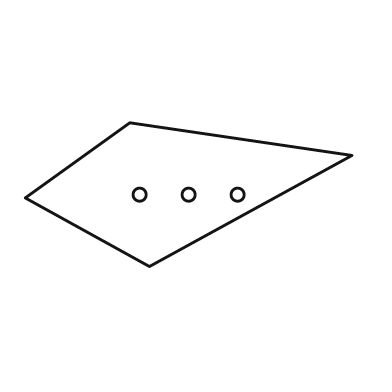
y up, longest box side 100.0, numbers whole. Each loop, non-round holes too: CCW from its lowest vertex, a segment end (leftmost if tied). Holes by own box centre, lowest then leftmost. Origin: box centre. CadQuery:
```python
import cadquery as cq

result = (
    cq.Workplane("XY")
    .moveTo(-12.0, -22.0)
    .lineTo(50.0, 12.0)
    .lineTo(-18.0, 22.0)
    .lineTo(-50.0, -1.0)
    .close()
    .moveTo(-15.0, 0.0)
    .circle(2.0)
    .moveTo(0.0, 0.0)
    .circle(2.0)
    .moveTo(15.0, 0.0)
    .circle(2.0)
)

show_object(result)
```